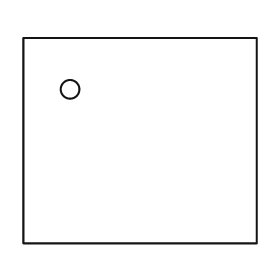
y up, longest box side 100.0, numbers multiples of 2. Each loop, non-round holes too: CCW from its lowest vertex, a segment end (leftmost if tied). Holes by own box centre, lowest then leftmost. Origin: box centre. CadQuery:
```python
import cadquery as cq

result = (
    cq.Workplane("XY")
    .moveTo(-50.0, -44.0)
    .lineTo(50.0, -44.0)
    .lineTo(50.0, 44.0)
    .lineTo(-50.0, 44.0)
    .close()
    .moveTo(-30.0, 22.0)
    .circle(4.0)
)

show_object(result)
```